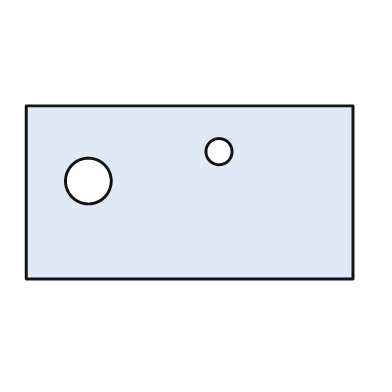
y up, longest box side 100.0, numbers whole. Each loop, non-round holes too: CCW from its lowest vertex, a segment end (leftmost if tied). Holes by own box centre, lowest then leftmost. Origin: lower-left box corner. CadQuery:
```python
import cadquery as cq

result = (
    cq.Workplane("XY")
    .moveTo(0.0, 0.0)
    .lineTo(100.0, 0.0)
    .lineTo(100.0, 53.0)
    .lineTo(0.0, 53.0)
    .close()
    .moveTo(19.0, 30.0)
    .circle(7.0)
    .moveTo(59.0, 39.0)
    .circle(4.0)
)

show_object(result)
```